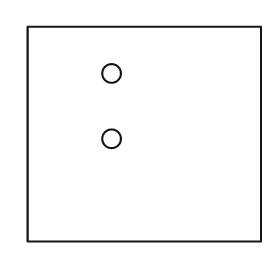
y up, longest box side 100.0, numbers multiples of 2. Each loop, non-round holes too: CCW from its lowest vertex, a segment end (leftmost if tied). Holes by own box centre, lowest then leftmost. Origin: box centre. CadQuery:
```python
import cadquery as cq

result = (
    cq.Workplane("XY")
    .moveTo(-50.0, -46.0)
    .lineTo(50.0, -46.0)
    .lineTo(50.0, 46.0)
    .lineTo(-50.0, 46.0)
    .close()
    .moveTo(-14.0, -2.0)
    .circle(4.0)
    .moveTo(-14.0, 26.0)
    .circle(4.0)
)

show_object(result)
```